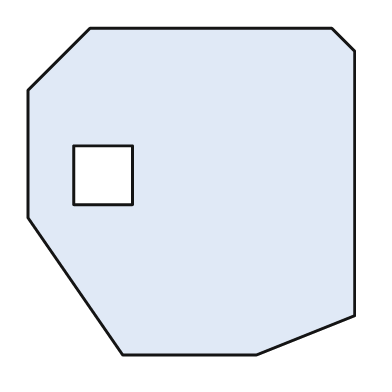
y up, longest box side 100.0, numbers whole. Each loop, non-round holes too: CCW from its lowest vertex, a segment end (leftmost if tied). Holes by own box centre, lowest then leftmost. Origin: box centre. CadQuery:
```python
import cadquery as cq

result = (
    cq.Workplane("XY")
    .moveTo(-21.0, -50.0)
    .lineTo(20.0, -50.0)
    .lineTo(50.0, -38.0)
    .lineTo(50.0, 43.0)
    .lineTo(43.0, 50.0)
    .lineTo(-31.0, 50.0)
    .lineTo(-50.0, 31.0)
    .lineTo(-50.0, -8.0)
    .close()
    .moveTo(-36.0, -4.0)
    .lineTo(-18.0, -4.0)
    .lineTo(-18.0, 14.0)
    .lineTo(-36.0, 14.0)
    .close()
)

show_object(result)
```